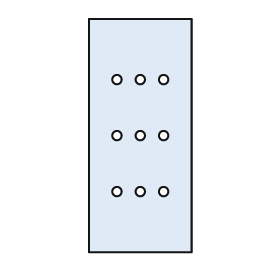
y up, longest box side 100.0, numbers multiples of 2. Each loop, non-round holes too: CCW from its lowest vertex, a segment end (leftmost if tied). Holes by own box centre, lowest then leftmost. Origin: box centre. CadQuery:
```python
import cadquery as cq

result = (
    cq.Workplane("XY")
    .moveTo(-22.0, -50.0)
    .lineTo(22.0, -50.0)
    .lineTo(22.0, 50.0)
    .lineTo(-22.0, 50.0)
    .close()
    .moveTo(-10.0, -24.0)
    .circle(2.0)
    .moveTo(0.0, -24.0)
    .circle(2.0)
    .moveTo(10.0, -24.0)
    .circle(2.0)
    .moveTo(-10.0, 0.0)
    .circle(2.0)
    .moveTo(0.0, 0.0)
    .circle(2.0)
    .moveTo(10.0, 0.0)
    .circle(2.0)
    .moveTo(-10.0, 24.0)
    .circle(2.0)
    .moveTo(0.0, 24.0)
    .circle(2.0)
    .moveTo(10.0, 24.0)
    .circle(2.0)
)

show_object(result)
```